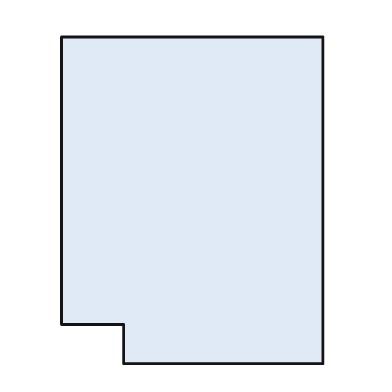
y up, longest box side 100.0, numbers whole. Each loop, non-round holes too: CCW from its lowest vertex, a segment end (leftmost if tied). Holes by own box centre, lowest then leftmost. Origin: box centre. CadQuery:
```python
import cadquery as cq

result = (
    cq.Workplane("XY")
    .moveTo(-21.0, -50.0)
    .lineTo(40.0, -50.0)
    .lineTo(40.0, 50.0)
    .lineTo(-40.0, 50.0)
    .lineTo(-40.0, -38.0)
    .lineTo(-21.0, -38.0)
    .close()
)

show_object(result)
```